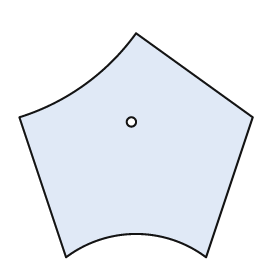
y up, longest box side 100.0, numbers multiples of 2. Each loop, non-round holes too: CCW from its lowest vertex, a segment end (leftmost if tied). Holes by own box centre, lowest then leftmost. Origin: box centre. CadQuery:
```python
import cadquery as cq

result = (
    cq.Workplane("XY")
    .moveTo(-30.0, -48.0)
    .threePointArc((0.0, -38.0), (30.0, -48.0))
    .lineTo(50.0, 12.0)
    .lineTo(0.0, 48.0)
    .threePointArc((-22.0, 26.0), (-50.0, 12.0))
    .close()
    .moveTo(-2.0, 10.0)
    .circle(2.0)
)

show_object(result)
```